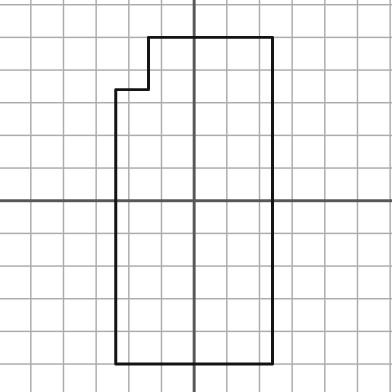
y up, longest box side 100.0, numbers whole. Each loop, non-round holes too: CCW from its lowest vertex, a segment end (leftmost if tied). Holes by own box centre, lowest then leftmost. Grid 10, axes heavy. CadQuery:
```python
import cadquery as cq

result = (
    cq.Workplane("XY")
    .moveTo(-24.0, -50.0)
    .lineTo(24.0, -50.0)
    .lineTo(24.0, 50.0)
    .lineTo(-14.0, 50.0)
    .lineTo(-14.0, 34.0)
    .lineTo(-24.0, 34.0)
    .close()
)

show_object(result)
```